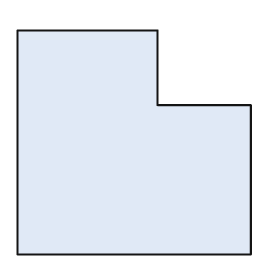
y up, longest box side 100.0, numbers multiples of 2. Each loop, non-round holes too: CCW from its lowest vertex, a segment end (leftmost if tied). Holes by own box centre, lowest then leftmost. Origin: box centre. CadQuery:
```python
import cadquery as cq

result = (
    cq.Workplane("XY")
    .moveTo(-50.0, -48.0)
    .lineTo(50.0, -48.0)
    .lineTo(50.0, 16.0)
    .lineTo(10.0, 16.0)
    .lineTo(10.0, 48.0)
    .lineTo(-50.0, 48.0)
    .close()
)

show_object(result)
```